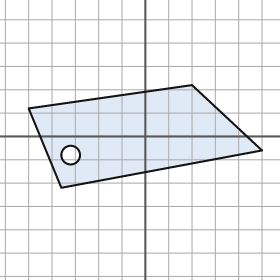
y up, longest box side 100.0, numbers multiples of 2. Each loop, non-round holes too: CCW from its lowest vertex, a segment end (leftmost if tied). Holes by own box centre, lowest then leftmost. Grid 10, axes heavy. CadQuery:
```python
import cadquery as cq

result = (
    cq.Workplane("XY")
    .moveTo(-36.0, -22.0)
    .lineTo(50.0, -6.0)
    .lineTo(20.0, 22.0)
    .lineTo(-50.0, 12.0)
    .close()
    .moveTo(-32.0, -8.0)
    .circle(4.0)
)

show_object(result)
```